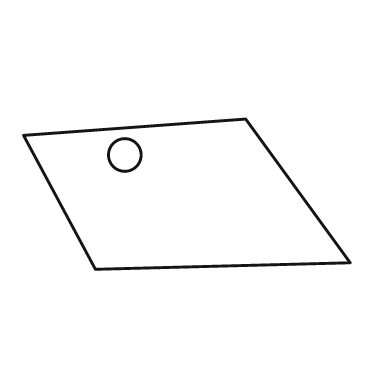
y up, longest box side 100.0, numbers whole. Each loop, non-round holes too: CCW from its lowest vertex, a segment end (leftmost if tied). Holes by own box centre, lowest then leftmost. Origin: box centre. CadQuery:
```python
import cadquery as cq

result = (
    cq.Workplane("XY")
    .moveTo(-28.0, -23.0)
    .lineTo(50.0, -21.0)
    .lineTo(18.0, 23.0)
    .lineTo(-50.0, 18.0)
    .close()
    .moveTo(-19.0, 12.0)
    .circle(5.0)
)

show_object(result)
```